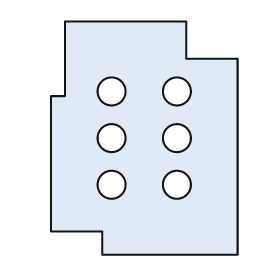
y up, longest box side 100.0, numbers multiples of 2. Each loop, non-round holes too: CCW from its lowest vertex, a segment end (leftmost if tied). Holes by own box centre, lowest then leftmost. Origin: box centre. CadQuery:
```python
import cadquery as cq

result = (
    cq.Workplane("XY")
    .moveTo(-18.0, -50.0)
    .lineTo(40.0, -50.0)
    .lineTo(40.0, 34.0)
    .lineTo(18.0, 34.0)
    .lineTo(18.0, 50.0)
    .lineTo(-34.0, 50.0)
    .lineTo(-34.0, 18.0)
    .lineTo(-40.0, 18.0)
    .lineTo(-40.0, -40.0)
    .lineTo(-18.0, -40.0)
    .close()
    .moveTo(-14.0, -20.0)
    .circle(6.0)
    .moveTo(14.0, -20.0)
    .circle(6.0)
    .moveTo(-14.0, 0.0)
    .circle(6.0)
    .moveTo(14.0, 0.0)
    .circle(6.0)
    .moveTo(-14.0, 20.0)
    .circle(6.0)
    .moveTo(14.0, 20.0)
    .circle(6.0)
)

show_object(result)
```